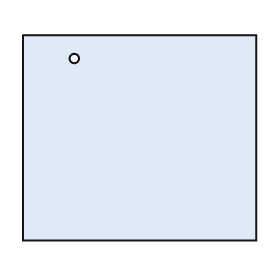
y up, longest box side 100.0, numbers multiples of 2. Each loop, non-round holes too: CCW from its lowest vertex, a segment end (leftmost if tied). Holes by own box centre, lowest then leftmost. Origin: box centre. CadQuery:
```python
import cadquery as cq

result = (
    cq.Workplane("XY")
    .moveTo(-50.0, -44.0)
    .lineTo(50.0, -44.0)
    .lineTo(50.0, 44.0)
    .lineTo(-50.0, 44.0)
    .close()
    .moveTo(-28.0, 34.0)
    .circle(2.0)
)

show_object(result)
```